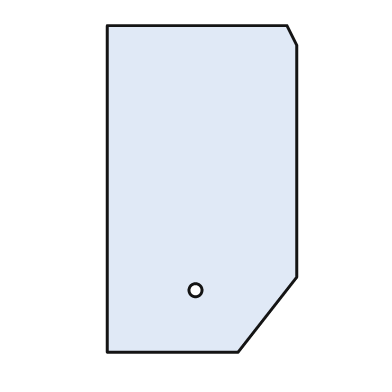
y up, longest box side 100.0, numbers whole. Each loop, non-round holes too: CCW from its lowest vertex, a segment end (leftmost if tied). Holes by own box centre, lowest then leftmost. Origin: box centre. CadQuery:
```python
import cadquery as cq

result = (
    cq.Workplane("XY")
    .moveTo(-29.0, -50.0)
    .lineTo(11.0, -50.0)
    .lineTo(29.0, -27.0)
    .lineTo(29.0, 44.0)
    .lineTo(26.0, 50.0)
    .lineTo(-29.0, 50.0)
    .close()
    .moveTo(-2.0, -31.0)
    .circle(2.0)
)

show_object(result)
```